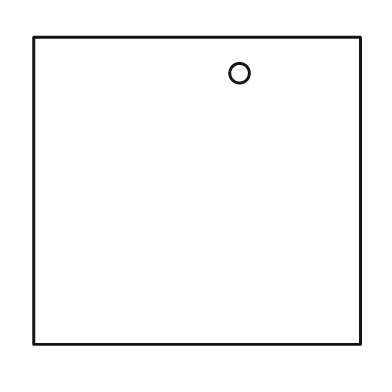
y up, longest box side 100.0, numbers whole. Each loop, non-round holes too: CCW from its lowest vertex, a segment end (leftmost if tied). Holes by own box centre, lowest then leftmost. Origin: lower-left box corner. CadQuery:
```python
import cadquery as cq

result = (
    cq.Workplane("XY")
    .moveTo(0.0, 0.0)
    .lineTo(100.0, 0.0)
    .lineTo(100.0, 94.0)
    .lineTo(0.0, 94.0)
    .close()
    .moveTo(63.0, 83.0)
    .circle(3.0)
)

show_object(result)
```